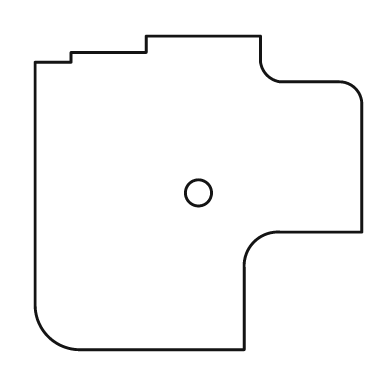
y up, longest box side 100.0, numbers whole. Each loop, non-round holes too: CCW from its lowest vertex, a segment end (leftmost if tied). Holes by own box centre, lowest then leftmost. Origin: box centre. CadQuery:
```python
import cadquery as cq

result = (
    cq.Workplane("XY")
    .moveTo(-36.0, -48.0)
    .lineTo(14.0, -48.0)
    .lineTo(14.0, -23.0)
    .threePointArc((17.0, -15.0), (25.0, -12.0))
    .lineTo(50.0, -12.0)
    .lineTo(50.0, 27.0)
    .threePointArc((48.0, 32.0), (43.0, 34.0))
    .lineTo(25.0, 34.0)
    .threePointArc((21.0, 36.0), (19.0, 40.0))
    .lineTo(19.0, 48.0)
    .lineTo(-16.0, 48.0)
    .lineTo(-16.0, 43.0)
    .lineTo(-39.0, 43.0)
    .lineTo(-39.0, 40.0)
    .lineTo(-50.0, 40.0)
    .lineTo(-50.0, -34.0)
    .threePointArc((-46.0, -44.0), (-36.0, -48.0))
    .close()
    .moveTo(0.0, 0.0)
    .circle(4.0)
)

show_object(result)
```